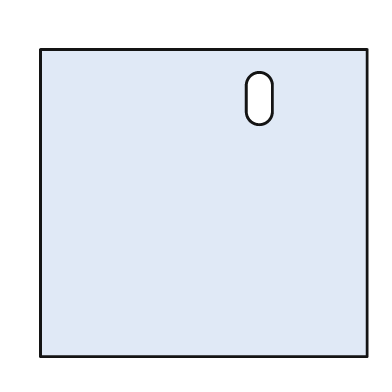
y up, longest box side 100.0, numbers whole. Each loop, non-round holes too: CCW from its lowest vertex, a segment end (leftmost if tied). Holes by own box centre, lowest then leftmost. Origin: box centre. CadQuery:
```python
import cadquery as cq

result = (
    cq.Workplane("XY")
    .moveTo(-50.0, -47.0)
    .lineTo(50.0, -47.0)
    .lineTo(50.0, 47.0)
    .lineTo(-50.0, 47.0)
    .close()
    .moveTo(13.0, 28.0)
    .threePointArc((17.0, 24.0), (21.0, 28.0))
    .lineTo(21.0, 36.0)
    .threePointArc((17.0, 40.0), (13.0, 36.0))
    .close()
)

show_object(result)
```